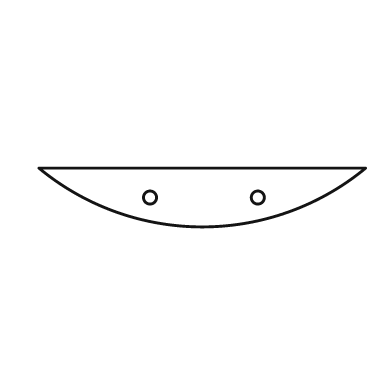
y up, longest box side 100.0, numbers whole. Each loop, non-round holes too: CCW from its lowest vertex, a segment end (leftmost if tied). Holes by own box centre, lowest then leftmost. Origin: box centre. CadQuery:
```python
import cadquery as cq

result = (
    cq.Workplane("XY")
    .moveTo(-50.0, 9.0)
    .threePointArc((0.0, -9.0), (50.0, 9.0))
    .close()
    .moveTo(-16.0, 0.0)
    .circle(2.0)
    .moveTo(17.0, 0.0)
    .circle(2.0)
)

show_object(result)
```